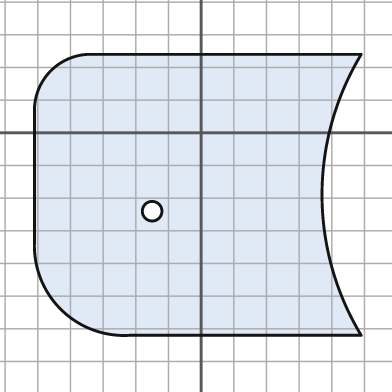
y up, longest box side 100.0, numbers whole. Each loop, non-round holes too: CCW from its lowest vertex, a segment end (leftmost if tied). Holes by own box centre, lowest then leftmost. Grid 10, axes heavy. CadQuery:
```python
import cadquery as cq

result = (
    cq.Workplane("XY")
    .moveTo(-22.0, -62.0)
    .lineTo(49.0, -62.0)
    .threePointArc((37.0, -19.0), (49.0, 24.0))
    .lineTo(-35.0, 24.0)
    .threePointArc((-46.0, 19.0), (-51.0, 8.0))
    .lineTo(-51.0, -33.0)
    .threePointArc((-43.0, -54.0), (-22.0, -62.0))
    .close()
    .moveTo(-15.0, -24.0)
    .circle(3.0)
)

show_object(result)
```